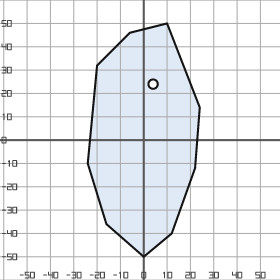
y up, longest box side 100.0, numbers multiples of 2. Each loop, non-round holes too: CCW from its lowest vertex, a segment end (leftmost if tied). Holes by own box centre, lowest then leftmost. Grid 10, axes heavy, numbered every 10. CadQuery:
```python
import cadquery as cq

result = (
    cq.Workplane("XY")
    .moveTo(0.0, -50.0)
    .lineTo(12.0, -40.0)
    .lineTo(22.0, -12.0)
    .lineTo(24.0, 14.0)
    .lineTo(10.0, 50.0)
    .lineTo(-6.0, 46.0)
    .lineTo(-20.0, 32.0)
    .lineTo(-24.0, -10.0)
    .lineTo(-16.0, -36.0)
    .close()
    .moveTo(4.0, 24.0)
    .circle(2.0)
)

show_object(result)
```